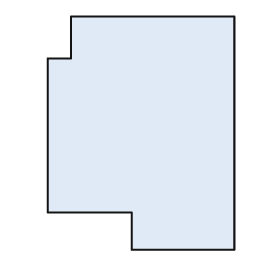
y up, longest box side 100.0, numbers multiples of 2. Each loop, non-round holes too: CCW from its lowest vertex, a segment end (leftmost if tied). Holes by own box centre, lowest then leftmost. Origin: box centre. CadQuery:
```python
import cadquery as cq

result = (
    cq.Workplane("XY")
    .moveTo(-4.0, -50.0)
    .lineTo(40.0, -50.0)
    .lineTo(40.0, 50.0)
    .lineTo(-30.0, 50.0)
    .lineTo(-30.0, 32.0)
    .lineTo(-40.0, 32.0)
    .lineTo(-40.0, -34.0)
    .lineTo(-4.0, -34.0)
    .close()
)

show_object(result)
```